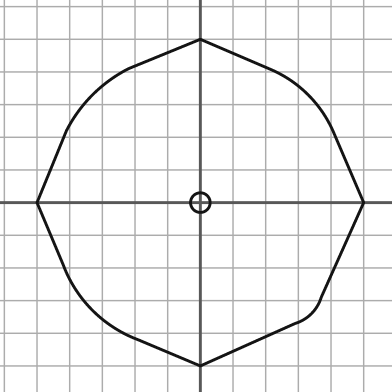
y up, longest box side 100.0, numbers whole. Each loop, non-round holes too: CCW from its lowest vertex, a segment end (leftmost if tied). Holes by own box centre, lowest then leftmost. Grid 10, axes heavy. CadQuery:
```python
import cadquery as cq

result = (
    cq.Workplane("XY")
    .moveTo(0.0, -50.0)
    .lineTo(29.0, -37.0)
    .threePointArc((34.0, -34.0), (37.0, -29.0))
    .lineTo(50.0, 0.0)
    .lineTo(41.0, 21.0)
    .threePointArc((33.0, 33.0), (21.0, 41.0))
    .lineTo(0.0, 50.0)
    .lineTo(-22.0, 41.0)
    .threePointArc((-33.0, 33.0), (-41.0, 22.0))
    .lineTo(-50.0, 0.0)
    .lineTo(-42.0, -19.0)
    .threePointArc((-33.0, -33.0), (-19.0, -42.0))
    .close()
    .moveTo(0.0, 0.0)
    .circle(3.0)
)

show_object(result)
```